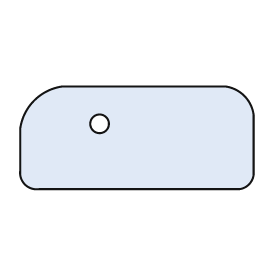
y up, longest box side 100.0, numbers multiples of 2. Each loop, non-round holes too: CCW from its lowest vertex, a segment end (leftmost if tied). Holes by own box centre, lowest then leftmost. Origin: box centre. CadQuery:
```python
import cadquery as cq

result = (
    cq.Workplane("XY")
    .moveTo(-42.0, -22.0)
    .lineTo(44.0, -22.0)
    .threePointArc((48.0, -20.0), (50.0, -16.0))
    .lineTo(50.0, 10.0)
    .threePointArc((46.0, 18.0), (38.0, 22.0))
    .lineTo(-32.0, 22.0)
    .threePointArc((-44.0, 16.0), (-50.0, 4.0))
    .lineTo(-50.0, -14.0)
    .threePointArc((-48.0, -20.0), (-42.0, -22.0))
    .close()
    .moveTo(-16.0, 6.0)
    .circle(4.0)
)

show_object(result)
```